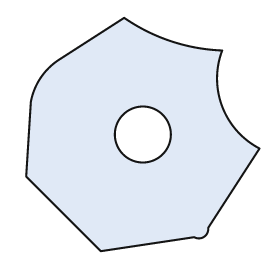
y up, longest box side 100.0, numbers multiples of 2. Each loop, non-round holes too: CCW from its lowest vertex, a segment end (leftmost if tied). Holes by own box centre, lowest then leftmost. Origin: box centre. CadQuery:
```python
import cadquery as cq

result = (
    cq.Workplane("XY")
    .moveTo(-18.0, -50.0)
    .lineTo(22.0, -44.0)
    .threePointArc((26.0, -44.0), (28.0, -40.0))
    .lineTo(50.0, -6.0)
    .threePointArc((34.0, 12.0), (34.0, 36.0))
    .threePointArc((12.0, 40.0), (-8.0, 50.0))
    .lineTo(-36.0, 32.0)
    .threePointArc((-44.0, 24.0), (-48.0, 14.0))
    .lineTo(-50.0, -18.0)
    .close()
    .moveTo(0.0, 0.0)
    .circle(12.0)
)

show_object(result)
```